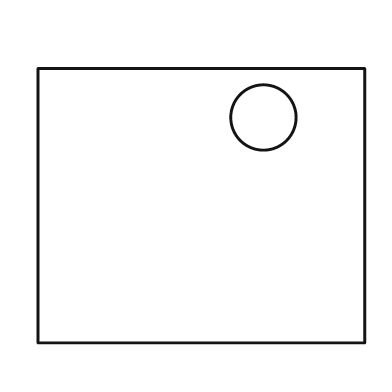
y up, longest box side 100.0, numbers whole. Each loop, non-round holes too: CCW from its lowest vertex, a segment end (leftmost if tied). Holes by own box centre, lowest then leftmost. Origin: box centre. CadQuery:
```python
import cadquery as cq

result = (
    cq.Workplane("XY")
    .moveTo(-50.0, -42.0)
    .lineTo(50.0, -42.0)
    .lineTo(50.0, 42.0)
    .lineTo(-50.0, 42.0)
    .close()
    .moveTo(19.0, 27.0)
    .circle(10.0)
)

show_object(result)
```